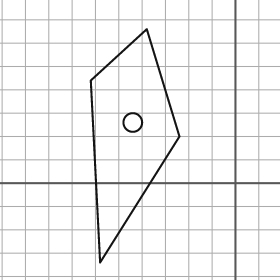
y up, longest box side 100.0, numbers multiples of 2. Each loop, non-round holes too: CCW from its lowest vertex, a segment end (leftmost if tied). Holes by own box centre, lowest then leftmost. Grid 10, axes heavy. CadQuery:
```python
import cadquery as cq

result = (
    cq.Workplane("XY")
    .moveTo(-58.0, -34.0)
    .lineTo(-24.0, 20.0)
    .lineTo(-38.0, 66.0)
    .lineTo(-62.0, 44.0)
    .close()
    .moveTo(-44.0, 26.0)
    .circle(4.0)
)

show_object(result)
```